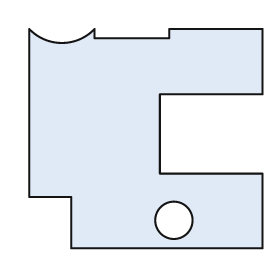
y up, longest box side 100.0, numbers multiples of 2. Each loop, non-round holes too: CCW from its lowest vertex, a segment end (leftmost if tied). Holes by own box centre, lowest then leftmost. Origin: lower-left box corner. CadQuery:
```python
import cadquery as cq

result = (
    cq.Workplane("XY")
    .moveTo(18.0, 0.0)
    .lineTo(100.0, 0.0)
    .lineTo(100.0, 32.0)
    .lineTo(56.0, 32.0)
    .lineTo(56.0, 66.0)
    .lineTo(100.0, 66.0)
    .lineTo(100.0, 94.0)
    .lineTo(60.0, 94.0)
    .lineTo(60.0, 90.0)
    .lineTo(28.0, 90.0)
    .lineTo(28.0, 94.0)
    .threePointArc((14.0, 88.0), (0.0, 94.0))
    .lineTo(0.0, 22.0)
    .lineTo(18.0, 22.0)
    .close()
    .moveTo(62.0, 12.0)
    .circle(8.0)
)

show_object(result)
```